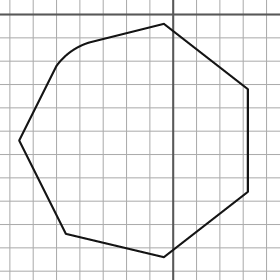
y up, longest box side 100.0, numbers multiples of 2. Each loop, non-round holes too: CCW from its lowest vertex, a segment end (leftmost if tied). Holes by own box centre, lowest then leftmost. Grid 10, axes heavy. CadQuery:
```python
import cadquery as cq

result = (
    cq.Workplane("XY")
    .moveTo(-4.0, -104.0)
    .lineTo(32.0, -76.0)
    .lineTo(32.0, -32.0)
    .lineTo(-4.0, -4.0)
    .lineTo(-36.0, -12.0)
    .threePointArc((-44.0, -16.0), (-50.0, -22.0))
    .lineTo(-66.0, -54.0)
    .lineTo(-46.0, -94.0)
    .close()
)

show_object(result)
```